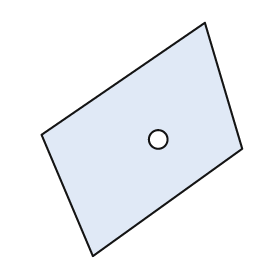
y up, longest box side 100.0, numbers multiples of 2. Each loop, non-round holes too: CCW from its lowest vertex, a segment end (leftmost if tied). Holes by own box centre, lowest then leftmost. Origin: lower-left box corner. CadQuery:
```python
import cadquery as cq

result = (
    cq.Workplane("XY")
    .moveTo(22.0, 0.0)
    .lineTo(86.0, 46.0)
    .lineTo(70.0, 100.0)
    .lineTo(0.0, 52.0)
    .close()
    .moveTo(50.0, 50.0)
    .circle(4.0)
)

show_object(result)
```